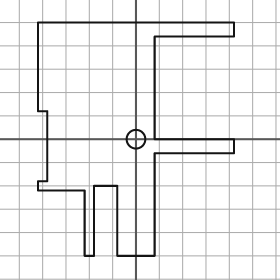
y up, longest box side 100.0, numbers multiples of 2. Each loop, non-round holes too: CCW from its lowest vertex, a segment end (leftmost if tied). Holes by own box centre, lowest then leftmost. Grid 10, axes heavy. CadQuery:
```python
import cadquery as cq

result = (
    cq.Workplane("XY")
    .moveTo(-22.0, -50.0)
    .lineTo(-18.0, -50.0)
    .lineTo(-18.0, -20.0)
    .lineTo(-8.0, -20.0)
    .lineTo(-8.0, -50.0)
    .lineTo(8.0, -50.0)
    .lineTo(8.0, -6.0)
    .lineTo(42.0, -6.0)
    .lineTo(42.0, 0.0)
    .lineTo(8.0, 0.0)
    .lineTo(8.0, 44.0)
    .lineTo(42.0, 44.0)
    .lineTo(42.0, 50.0)
    .lineTo(-42.0, 50.0)
    .lineTo(-42.0, 12.0)
    .lineTo(-38.0, 12.0)
    .lineTo(-38.0, -18.0)
    .lineTo(-42.0, -18.0)
    .lineTo(-42.0, -22.0)
    .lineTo(-22.0, -22.0)
    .close()
    .moveTo(0.0, 0.0)
    .circle(4.0)
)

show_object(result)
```